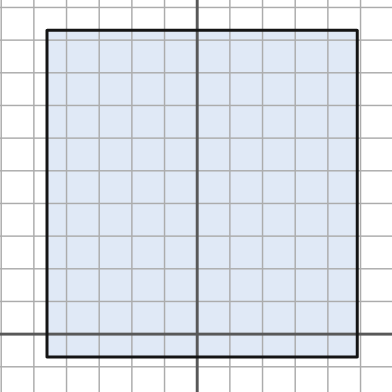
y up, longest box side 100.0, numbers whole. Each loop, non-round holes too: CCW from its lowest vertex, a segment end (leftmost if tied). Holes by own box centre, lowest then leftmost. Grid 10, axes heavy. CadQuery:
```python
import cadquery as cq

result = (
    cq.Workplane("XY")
    .moveTo(-46.0, -7.0)
    .lineTo(49.0, -7.0)
    .lineTo(49.0, 93.0)
    .lineTo(-46.0, 93.0)
    .close()
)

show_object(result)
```